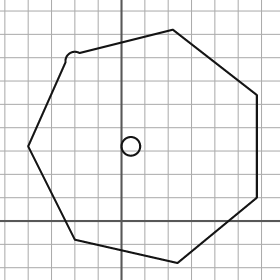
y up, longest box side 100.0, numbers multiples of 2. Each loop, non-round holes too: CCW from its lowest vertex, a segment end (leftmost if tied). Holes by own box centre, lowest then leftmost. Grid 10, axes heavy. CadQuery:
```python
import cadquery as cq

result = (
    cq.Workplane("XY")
    .moveTo(24.0, -18.0)
    .lineTo(58.0, 10.0)
    .lineTo(58.0, 54.0)
    .lineTo(22.0, 82.0)
    .lineTo(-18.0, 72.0)
    .threePointArc((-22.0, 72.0), (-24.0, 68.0))
    .lineTo(-40.0, 32.0)
    .lineTo(-20.0, -8.0)
    .close()
    .moveTo(4.0, 32.0)
    .circle(4.0)
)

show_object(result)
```